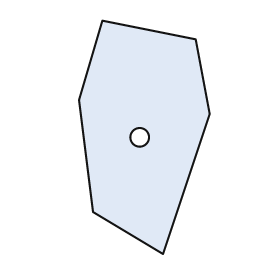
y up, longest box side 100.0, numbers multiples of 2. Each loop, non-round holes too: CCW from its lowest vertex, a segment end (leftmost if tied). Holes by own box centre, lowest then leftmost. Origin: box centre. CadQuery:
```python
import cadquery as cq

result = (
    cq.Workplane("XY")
    .moveTo(8.0, -50.0)
    .lineTo(28.0, 10.0)
    .lineTo(22.0, 42.0)
    .lineTo(-18.0, 50.0)
    .lineTo(-28.0, 16.0)
    .lineTo(-22.0, -32.0)
    .close()
    .moveTo(-2.0, 0.0)
    .circle(4.0)
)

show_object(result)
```